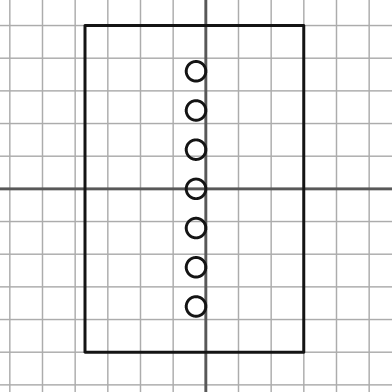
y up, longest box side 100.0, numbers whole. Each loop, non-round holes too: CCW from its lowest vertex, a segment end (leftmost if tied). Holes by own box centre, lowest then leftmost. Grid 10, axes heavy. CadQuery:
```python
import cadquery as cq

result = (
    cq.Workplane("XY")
    .moveTo(-37.0, -50.0)
    .lineTo(30.0, -50.0)
    .lineTo(30.0, 50.0)
    .lineTo(-37.0, 50.0)
    .close()
    .moveTo(-3.0, -36.0)
    .circle(3.0)
    .moveTo(-3.0, -24.0)
    .circle(3.0)
    .moveTo(-3.0, -12.0)
    .circle(3.0)
    .moveTo(-3.0, 0.0)
    .circle(3.0)
    .moveTo(-3.0, 12.0)
    .circle(3.0)
    .moveTo(-3.0, 24.0)
    .circle(3.0)
    .moveTo(-3.0, 36.0)
    .circle(3.0)
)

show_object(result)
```